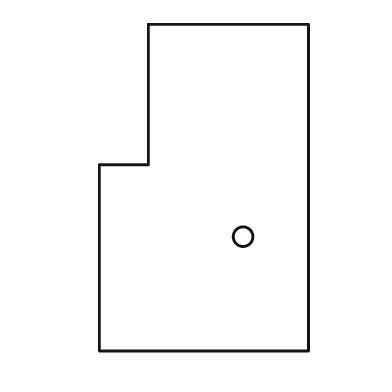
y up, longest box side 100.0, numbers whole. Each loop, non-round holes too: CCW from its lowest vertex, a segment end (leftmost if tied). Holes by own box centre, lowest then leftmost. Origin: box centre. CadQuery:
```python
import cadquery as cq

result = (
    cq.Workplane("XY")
    .moveTo(-32.0, -50.0)
    .lineTo(32.0, -50.0)
    .lineTo(32.0, 50.0)
    .lineTo(-17.0, 50.0)
    .lineTo(-17.0, 7.0)
    .lineTo(-32.0, 7.0)
    .close()
    .moveTo(12.0, -15.0)
    .circle(3.0)
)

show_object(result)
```